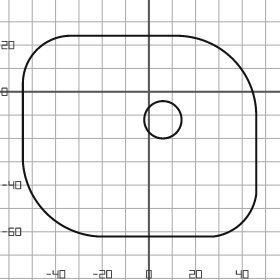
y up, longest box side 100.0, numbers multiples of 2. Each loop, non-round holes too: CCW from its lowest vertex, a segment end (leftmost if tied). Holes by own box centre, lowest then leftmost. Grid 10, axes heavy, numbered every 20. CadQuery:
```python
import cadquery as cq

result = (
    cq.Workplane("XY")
    .moveTo(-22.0, -62.0)
    .lineTo(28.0, -62.0)
    .threePointArc((40.0, -56.0), (46.0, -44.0))
    .lineTo(46.0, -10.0)
    .threePointArc((36.0, 14.0), (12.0, 24.0))
    .lineTo(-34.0, 24.0)
    .threePointArc((-48.0, 18.0), (-54.0, 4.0))
    .lineTo(-54.0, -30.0)
    .threePointArc((-44.0, -52.0), (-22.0, -62.0))
    .close()
    .moveTo(6.0, -12.0)
    .circle(8.0)
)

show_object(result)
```